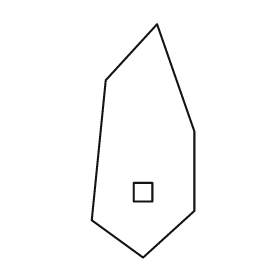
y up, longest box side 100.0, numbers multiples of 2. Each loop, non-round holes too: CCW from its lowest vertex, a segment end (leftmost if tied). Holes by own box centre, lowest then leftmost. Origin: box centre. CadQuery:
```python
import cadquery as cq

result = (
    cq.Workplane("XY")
    .moveTo(0.0, -50.0)
    .lineTo(22.0, -30.0)
    .lineTo(22.0, 4.0)
    .lineTo(6.0, 50.0)
    .lineTo(-16.0, 26.0)
    .lineTo(-22.0, -34.0)
    .close()
    .moveTo(-4.0, -26.0)
    .lineTo(4.0, -26.0)
    .lineTo(4.0, -18.0)
    .lineTo(-4.0, -18.0)
    .close()
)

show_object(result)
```